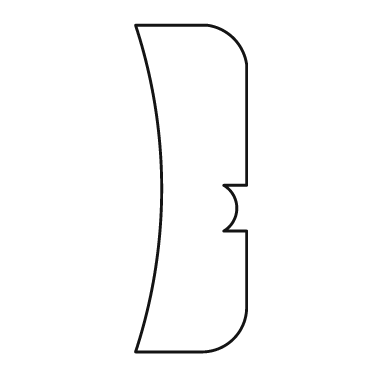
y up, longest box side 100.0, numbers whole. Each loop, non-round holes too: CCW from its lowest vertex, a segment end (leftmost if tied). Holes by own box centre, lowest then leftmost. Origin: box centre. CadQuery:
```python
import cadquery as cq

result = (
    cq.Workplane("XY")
    .moveTo(-17.0, -50.0)
    .lineTo(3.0, -50.0)
    .threePointArc((13.0, -46.0), (17.0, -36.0))
    .lineTo(17.0, -13.0)
    .lineTo(10.0, -13.0)
    .threePointArc((14.0, -6.0), (10.0, 1.0))
    .lineTo(17.0, 1.0)
    .lineTo(17.0, 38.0)
    .threePointArc((13.0, 46.0), (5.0, 50.0))
    .lineTo(-17.0, 50.0)
    .threePointArc((-9.0, 0.0), (-17.0, -50.0))
    .close()
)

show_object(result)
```